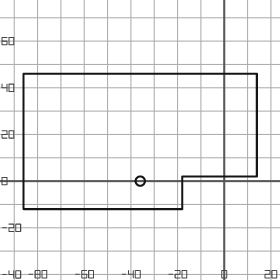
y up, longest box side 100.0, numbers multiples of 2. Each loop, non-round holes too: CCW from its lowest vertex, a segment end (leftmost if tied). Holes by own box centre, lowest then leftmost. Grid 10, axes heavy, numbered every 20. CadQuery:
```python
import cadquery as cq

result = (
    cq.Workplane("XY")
    .moveTo(-86.0, -12.0)
    .lineTo(-18.0, -12.0)
    .lineTo(-18.0, 2.0)
    .lineTo(14.0, 2.0)
    .lineTo(14.0, 46.0)
    .lineTo(-86.0, 46.0)
    .close()
    .moveTo(-36.0, 0.0)
    .circle(2.0)
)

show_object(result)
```